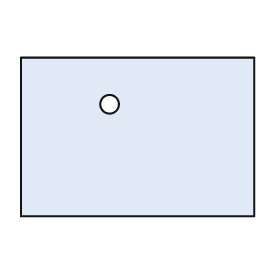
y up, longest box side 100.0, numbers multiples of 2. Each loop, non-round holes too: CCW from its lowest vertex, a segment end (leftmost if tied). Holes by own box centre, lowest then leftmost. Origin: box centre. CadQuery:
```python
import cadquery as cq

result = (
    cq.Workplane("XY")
    .moveTo(-50.0, -34.0)
    .lineTo(50.0, -34.0)
    .lineTo(50.0, 34.0)
    .lineTo(-50.0, 34.0)
    .close()
    .moveTo(-12.0, 14.0)
    .circle(4.0)
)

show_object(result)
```